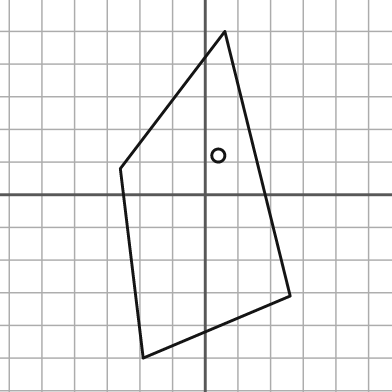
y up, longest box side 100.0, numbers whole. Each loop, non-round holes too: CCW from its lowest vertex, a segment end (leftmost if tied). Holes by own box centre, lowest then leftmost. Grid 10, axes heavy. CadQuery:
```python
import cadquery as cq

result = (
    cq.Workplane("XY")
    .moveTo(-19.0, -50.0)
    .lineTo(26.0, -31.0)
    .lineTo(6.0, 50.0)
    .lineTo(-26.0, 8.0)
    .close()
    .moveTo(4.0, 12.0)
    .circle(2.0)
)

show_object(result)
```